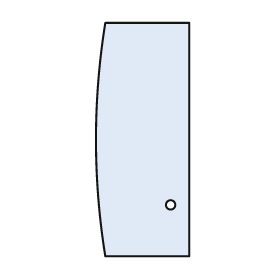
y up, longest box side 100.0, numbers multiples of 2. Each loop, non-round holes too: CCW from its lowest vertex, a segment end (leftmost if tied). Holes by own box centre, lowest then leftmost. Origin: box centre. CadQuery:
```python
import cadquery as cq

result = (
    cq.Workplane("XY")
    .moveTo(-16.0, -50.0)
    .lineTo(20.0, -50.0)
    .lineTo(20.0, 50.0)
    .lineTo(-16.0, 50.0)
    .threePointArc((-20.0, 0.0), (-16.0, -50.0))
    .close()
    .moveTo(12.0, -28.0)
    .circle(2.0)
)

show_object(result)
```